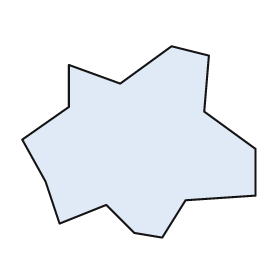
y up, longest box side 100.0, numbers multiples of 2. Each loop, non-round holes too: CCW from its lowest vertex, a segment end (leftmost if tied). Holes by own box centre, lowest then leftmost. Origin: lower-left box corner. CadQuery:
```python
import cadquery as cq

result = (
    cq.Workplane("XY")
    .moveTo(60.0, 0.0)
    .lineTo(70.0, 16.0)
    .lineTo(100.0, 18.0)
    .lineTo(100.0, 38.0)
    .lineTo(78.0, 54.0)
    .lineTo(80.0, 78.0)
    .lineTo(64.0, 82.0)
    .lineTo(42.0, 66.0)
    .lineTo(20.0, 74.0)
    .lineTo(20.0, 56.0)
    .lineTo(0.0, 42.0)
    .lineTo(10.0, 24.0)
    .lineTo(16.0, 6.0)
    .lineTo(36.0, 14.0)
    .lineTo(48.0, 2.0)
    .close()
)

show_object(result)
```